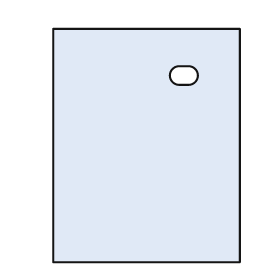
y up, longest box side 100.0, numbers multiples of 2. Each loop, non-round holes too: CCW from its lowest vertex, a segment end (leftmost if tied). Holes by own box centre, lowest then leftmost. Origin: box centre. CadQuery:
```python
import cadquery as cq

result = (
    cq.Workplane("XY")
    .moveTo(-40.0, -50.0)
    .lineTo(40.0, -50.0)
    .lineTo(40.0, 50.0)
    .lineTo(-40.0, 50.0)
    .close()
    .moveTo(14.0, 26.0)
    .lineTo(18.0, 26.0)
    .threePointArc((22.0, 30.0), (18.0, 34.0))
    .lineTo(14.0, 34.0)
    .threePointArc((10.0, 30.0), (14.0, 26.0))
    .close()
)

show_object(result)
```